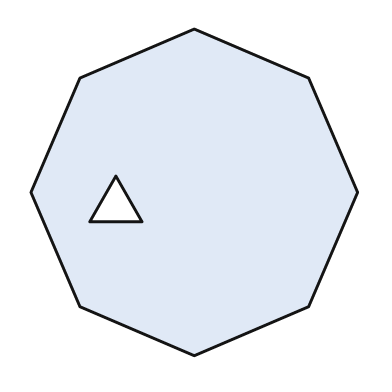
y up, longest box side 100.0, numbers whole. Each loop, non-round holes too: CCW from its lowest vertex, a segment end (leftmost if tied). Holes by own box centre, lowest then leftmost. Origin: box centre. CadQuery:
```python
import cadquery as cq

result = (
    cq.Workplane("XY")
    .moveTo(0.0, -50.0)
    .lineTo(35.0, -35.0)
    .lineTo(50.0, 0.0)
    .lineTo(35.0, 35.0)
    .lineTo(0.0, 50.0)
    .lineTo(-35.0, 35.0)
    .lineTo(-50.0, 0.0)
    .lineTo(-35.0, -35.0)
    .close()
    .moveTo(-32.0, -9.0)
    .lineTo(-16.0, -9.0)
    .lineTo(-24.0, 5.0)
    .close()
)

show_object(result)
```